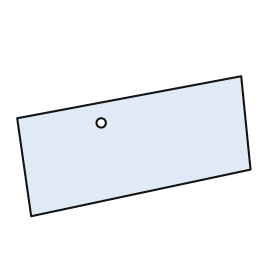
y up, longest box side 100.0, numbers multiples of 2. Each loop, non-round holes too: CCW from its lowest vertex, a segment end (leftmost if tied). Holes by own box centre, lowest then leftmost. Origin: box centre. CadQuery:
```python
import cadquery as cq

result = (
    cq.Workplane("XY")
    .moveTo(-44.0, -30.0)
    .lineTo(50.0, -10.0)
    .lineTo(46.0, 30.0)
    .lineTo(-50.0, 12.0)
    .close()
    .moveTo(-14.0, 10.0)
    .circle(2.0)
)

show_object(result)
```